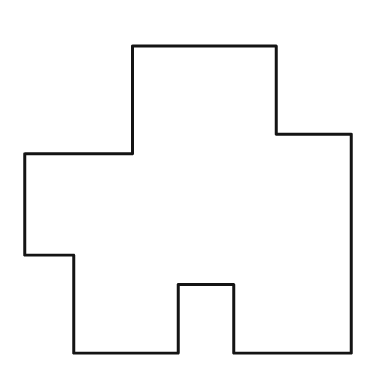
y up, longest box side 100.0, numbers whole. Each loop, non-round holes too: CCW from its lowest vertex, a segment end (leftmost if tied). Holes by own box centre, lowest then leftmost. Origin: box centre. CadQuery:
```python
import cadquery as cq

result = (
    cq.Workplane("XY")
    .moveTo(-35.0, -47.0)
    .lineTo(-3.0, -47.0)
    .lineTo(-3.0, -26.0)
    .lineTo(14.0, -26.0)
    .lineTo(14.0, -47.0)
    .lineTo(50.0, -47.0)
    .lineTo(50.0, 20.0)
    .lineTo(27.0, 20.0)
    .lineTo(27.0, 47.0)
    .lineTo(-17.0, 47.0)
    .lineTo(-17.0, 14.0)
    .lineTo(-50.0, 14.0)
    .lineTo(-50.0, -17.0)
    .lineTo(-35.0, -17.0)
    .close()
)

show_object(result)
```